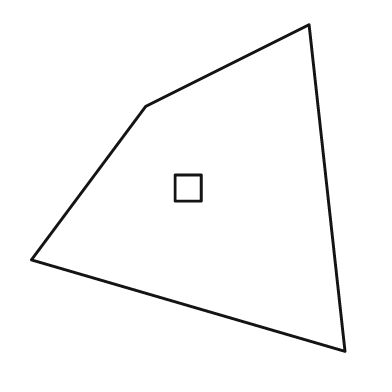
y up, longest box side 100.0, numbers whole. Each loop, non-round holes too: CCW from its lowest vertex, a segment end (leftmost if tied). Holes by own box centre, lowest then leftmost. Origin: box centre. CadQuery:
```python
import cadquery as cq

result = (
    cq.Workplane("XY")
    .moveTo(48.0, -50.0)
    .lineTo(37.0, 50.0)
    .lineTo(-13.0, 25.0)
    .lineTo(-48.0, -22.0)
    .close()
    .moveTo(-4.0, -4.0)
    .lineTo(4.0, -4.0)
    .lineTo(4.0, 4.0)
    .lineTo(-4.0, 4.0)
    .close()
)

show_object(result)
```